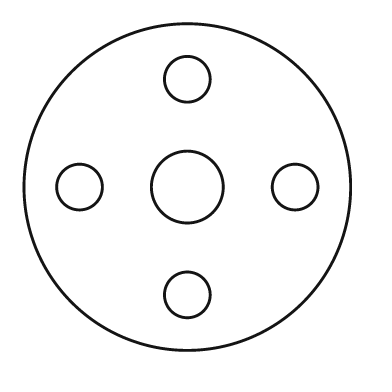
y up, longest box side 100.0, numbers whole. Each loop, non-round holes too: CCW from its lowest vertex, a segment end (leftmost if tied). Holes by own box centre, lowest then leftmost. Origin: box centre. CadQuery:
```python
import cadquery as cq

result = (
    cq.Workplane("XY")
    .moveTo(0.0, 0.0)
    .circle(50.0)
    .moveTo(0.0, -33.0)
    .circle(7.0)
    .moveTo(-33.0, 0.0)
    .circle(7.0)
    .moveTo(0.0, 0.0)
    .circle(11.0)
    .moveTo(33.0, 0.0)
    .circle(7.0)
    .moveTo(0.0, 33.0)
    .circle(7.0)
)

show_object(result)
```